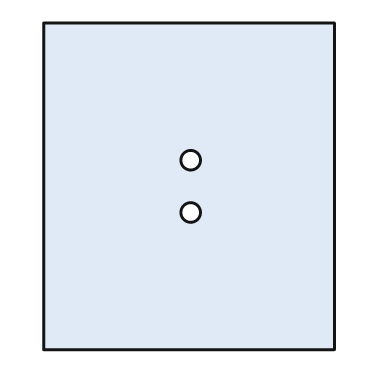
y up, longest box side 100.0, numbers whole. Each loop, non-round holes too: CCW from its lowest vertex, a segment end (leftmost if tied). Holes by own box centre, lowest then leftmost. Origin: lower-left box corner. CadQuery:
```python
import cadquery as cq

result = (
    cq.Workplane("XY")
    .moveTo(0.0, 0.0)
    .lineTo(89.0, 0.0)
    .lineTo(89.0, 100.0)
    .lineTo(0.0, 100.0)
    .close()
    .moveTo(45.0, 42.0)
    .circle(3.0)
    .moveTo(45.0, 58.0)
    .circle(3.0)
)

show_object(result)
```